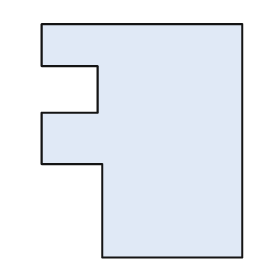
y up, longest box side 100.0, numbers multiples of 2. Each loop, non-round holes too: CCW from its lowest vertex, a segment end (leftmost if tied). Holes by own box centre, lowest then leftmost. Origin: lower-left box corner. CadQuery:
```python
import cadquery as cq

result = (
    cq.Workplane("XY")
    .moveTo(26.0, 0.0)
    .lineTo(86.0, 0.0)
    .lineTo(86.0, 100.0)
    .lineTo(0.0, 100.0)
    .lineTo(0.0, 82.0)
    .lineTo(24.0, 82.0)
    .lineTo(24.0, 62.0)
    .lineTo(0.0, 62.0)
    .lineTo(0.0, 40.0)
    .lineTo(26.0, 40.0)
    .close()
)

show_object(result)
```